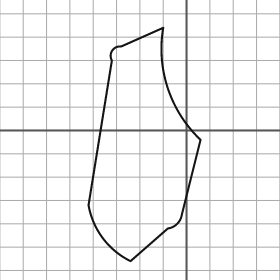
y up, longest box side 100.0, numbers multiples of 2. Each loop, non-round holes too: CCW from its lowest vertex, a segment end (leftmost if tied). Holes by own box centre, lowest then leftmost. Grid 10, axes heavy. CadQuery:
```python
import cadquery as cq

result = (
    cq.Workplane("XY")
    .moveTo(-24.0, -56.0)
    .lineTo(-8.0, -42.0)
    .threePointArc((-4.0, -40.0), (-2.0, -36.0))
    .lineTo(6.0, -4.0)
    .threePointArc((-8.0, 18.0), (-10.0, 44.0))
    .lineTo(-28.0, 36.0)
    .threePointArc((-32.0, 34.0), (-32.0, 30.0))
    .lineTo(-42.0, -32.0)
    .threePointArc((-36.0, -46.0), (-24.0, -56.0))
    .close()
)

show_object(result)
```